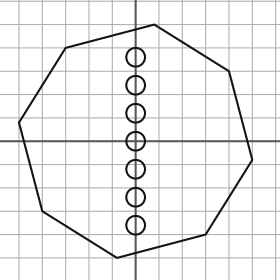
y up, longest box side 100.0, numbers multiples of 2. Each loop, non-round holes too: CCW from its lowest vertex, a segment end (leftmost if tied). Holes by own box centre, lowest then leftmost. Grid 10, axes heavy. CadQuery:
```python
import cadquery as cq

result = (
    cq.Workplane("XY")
    .moveTo(-8.0, -50.0)
    .lineTo(30.0, -40.0)
    .lineTo(50.0, -8.0)
    .lineTo(40.0, 30.0)
    .lineTo(8.0, 50.0)
    .lineTo(-30.0, 40.0)
    .lineTo(-50.0, 8.0)
    .lineTo(-40.0, -30.0)
    .close()
    .moveTo(0.0, -36.0)
    .circle(4.0)
    .moveTo(0.0, -24.0)
    .circle(4.0)
    .moveTo(0.0, -12.0)
    .circle(4.0)
    .moveTo(0.0, 0.0)
    .circle(4.0)
    .moveTo(0.0, 12.0)
    .circle(4.0)
    .moveTo(0.0, 24.0)
    .circle(4.0)
    .moveTo(0.0, 36.0)
    .circle(4.0)
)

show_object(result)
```